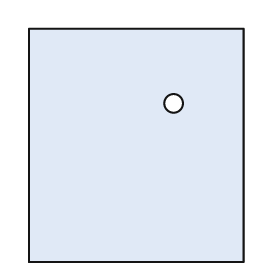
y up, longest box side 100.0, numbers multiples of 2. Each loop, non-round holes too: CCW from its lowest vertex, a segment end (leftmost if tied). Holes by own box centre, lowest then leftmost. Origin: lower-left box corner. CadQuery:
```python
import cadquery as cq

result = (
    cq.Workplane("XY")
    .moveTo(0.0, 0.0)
    .lineTo(92.0, 0.0)
    .lineTo(92.0, 100.0)
    .lineTo(0.0, 100.0)
    .close()
    .moveTo(62.0, 68.0)
    .circle(4.0)
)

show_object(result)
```